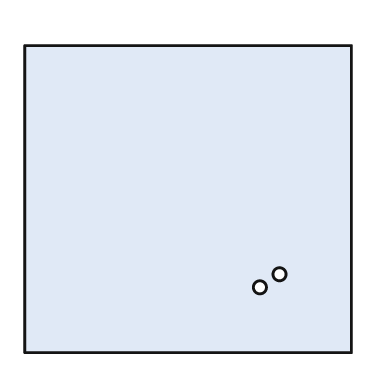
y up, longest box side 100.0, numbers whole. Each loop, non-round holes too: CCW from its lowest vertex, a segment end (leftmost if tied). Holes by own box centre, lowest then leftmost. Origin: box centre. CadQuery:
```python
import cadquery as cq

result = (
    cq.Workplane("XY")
    .moveTo(-50.0, -47.0)
    .lineTo(50.0, -47.0)
    .lineTo(50.0, 47.0)
    .lineTo(-50.0, 47.0)
    .close()
    .moveTo(22.0, -27.0)
    .circle(2.0)
    .moveTo(28.0, -23.0)
    .circle(2.0)
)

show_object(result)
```